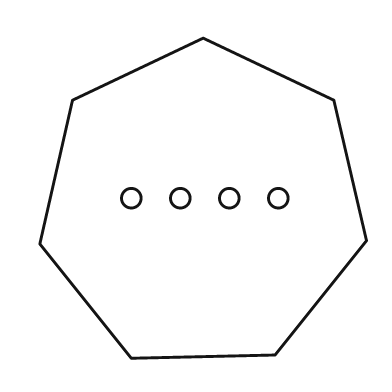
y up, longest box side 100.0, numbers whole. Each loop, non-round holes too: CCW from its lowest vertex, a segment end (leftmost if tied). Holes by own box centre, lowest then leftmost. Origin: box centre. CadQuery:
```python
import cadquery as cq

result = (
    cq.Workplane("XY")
    .moveTo(-22.0, -49.0)
    .lineTo(22.0, -48.0)
    .lineTo(50.0, -13.0)
    .lineTo(40.0, 30.0)
    .lineTo(0.0, 49.0)
    .lineTo(-40.0, 30.0)
    .lineTo(-50.0, -14.0)
    .close()
    .moveTo(-22.0, 0.0)
    .circle(3.0)
    .moveTo(-7.0, 0.0)
    .circle(3.0)
    .moveTo(8.0, 0.0)
    .circle(3.0)
    .moveTo(23.0, 0.0)
    .circle(3.0)
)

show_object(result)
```